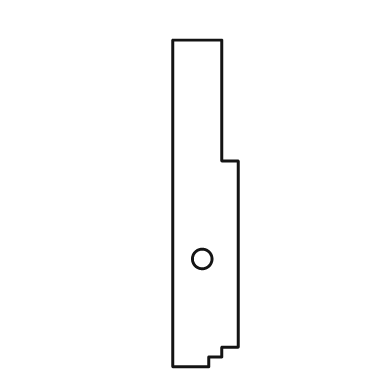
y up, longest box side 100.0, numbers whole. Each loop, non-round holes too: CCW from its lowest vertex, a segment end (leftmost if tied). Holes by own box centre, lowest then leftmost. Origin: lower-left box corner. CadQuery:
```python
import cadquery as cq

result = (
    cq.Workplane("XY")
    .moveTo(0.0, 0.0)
    .lineTo(11.0, 0.0)
    .lineTo(11.0, 3.0)
    .lineTo(15.0, 3.0)
    .lineTo(15.0, 6.0)
    .lineTo(20.0, 6.0)
    .lineTo(20.0, 63.0)
    .lineTo(15.0, 63.0)
    .lineTo(15.0, 100.0)
    .lineTo(0.0, 100.0)
    .close()
    .moveTo(9.0, 33.0)
    .circle(3.0)
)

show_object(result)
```